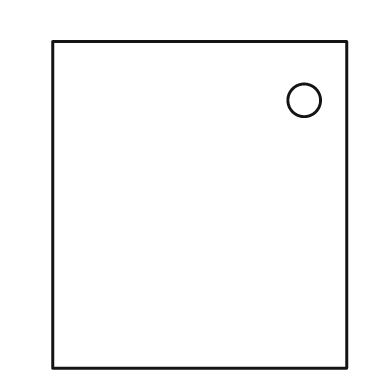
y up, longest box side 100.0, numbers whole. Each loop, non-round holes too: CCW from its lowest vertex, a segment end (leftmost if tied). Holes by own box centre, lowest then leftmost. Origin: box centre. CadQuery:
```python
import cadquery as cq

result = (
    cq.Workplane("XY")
    .moveTo(-45.0, -50.0)
    .lineTo(45.0, -50.0)
    .lineTo(45.0, 50.0)
    .lineTo(-45.0, 50.0)
    .close()
    .moveTo(32.0, 32.0)
    .circle(5.0)
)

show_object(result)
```